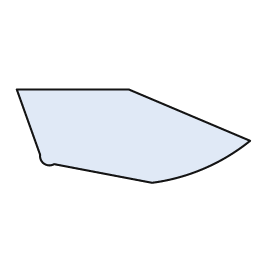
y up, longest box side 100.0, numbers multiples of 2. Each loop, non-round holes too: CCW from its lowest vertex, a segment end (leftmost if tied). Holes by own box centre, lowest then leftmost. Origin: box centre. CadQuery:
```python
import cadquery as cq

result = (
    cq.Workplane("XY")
    .moveTo(8.0, -20.0)
    .threePointArc((30.0, -14.0), (50.0, -2.0))
    .lineTo(-2.0, 20.0)
    .lineTo(-50.0, 20.0)
    .lineTo(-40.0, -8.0)
    .threePointArc((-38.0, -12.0), (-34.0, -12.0))
    .close()
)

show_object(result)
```